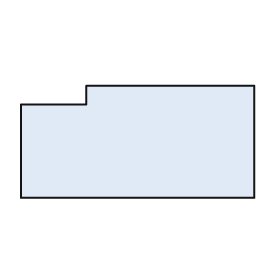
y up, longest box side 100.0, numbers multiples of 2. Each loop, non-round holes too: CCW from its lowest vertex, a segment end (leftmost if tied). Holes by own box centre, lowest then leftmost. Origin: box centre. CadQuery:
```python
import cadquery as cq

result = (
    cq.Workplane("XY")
    .moveTo(-50.0, -24.0)
    .lineTo(50.0, -24.0)
    .lineTo(50.0, 24.0)
    .lineTo(-22.0, 24.0)
    .lineTo(-22.0, 16.0)
    .lineTo(-50.0, 16.0)
    .close()
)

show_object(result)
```